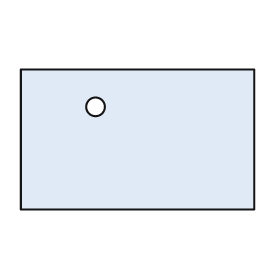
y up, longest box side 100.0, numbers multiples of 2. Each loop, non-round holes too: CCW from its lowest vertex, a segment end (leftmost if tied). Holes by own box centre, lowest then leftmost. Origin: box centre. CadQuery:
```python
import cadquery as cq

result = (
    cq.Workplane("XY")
    .moveTo(-50.0, -30.0)
    .lineTo(50.0, -30.0)
    .lineTo(50.0, 30.0)
    .lineTo(-50.0, 30.0)
    .close()
    .moveTo(-18.0, 14.0)
    .circle(4.0)
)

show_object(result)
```